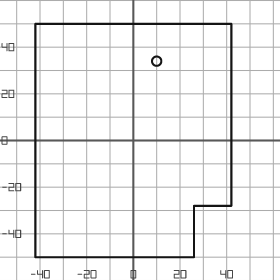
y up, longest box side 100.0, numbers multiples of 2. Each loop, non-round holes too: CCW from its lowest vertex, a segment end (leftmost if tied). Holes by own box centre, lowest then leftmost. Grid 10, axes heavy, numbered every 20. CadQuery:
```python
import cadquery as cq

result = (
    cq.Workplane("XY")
    .moveTo(-42.0, -50.0)
    .lineTo(26.0, -50.0)
    .lineTo(26.0, -28.0)
    .lineTo(42.0, -28.0)
    .lineTo(42.0, 50.0)
    .lineTo(-42.0, 50.0)
    .close()
    .moveTo(10.0, 34.0)
    .circle(2.0)
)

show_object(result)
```